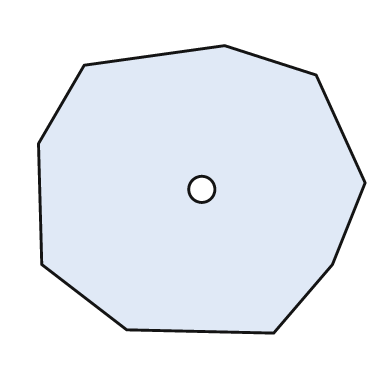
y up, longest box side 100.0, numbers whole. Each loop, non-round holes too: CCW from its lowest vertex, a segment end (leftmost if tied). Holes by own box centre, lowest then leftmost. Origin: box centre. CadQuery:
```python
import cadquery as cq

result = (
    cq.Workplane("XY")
    .moveTo(22.0, -44.0)
    .lineTo(40.0, -23.0)
    .lineTo(50.0, 2.0)
    .lineTo(35.0, 35.0)
    .lineTo(7.0, 44.0)
    .lineTo(-36.0, 38.0)
    .lineTo(-50.0, 14.0)
    .lineTo(-49.0, -23.0)
    .lineTo(-23.0, -43.0)
    .close()
    .moveTo(0.0, 0.0)
    .circle(4.0)
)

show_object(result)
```